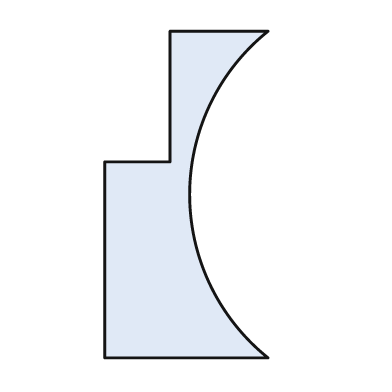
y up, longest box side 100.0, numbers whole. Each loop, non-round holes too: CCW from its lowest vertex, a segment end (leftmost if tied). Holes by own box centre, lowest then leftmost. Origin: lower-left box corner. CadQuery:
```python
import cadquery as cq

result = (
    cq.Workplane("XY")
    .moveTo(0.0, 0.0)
    .lineTo(50.0, 0.0)
    .threePointArc((26.0, 50.0), (50.0, 100.0))
    .lineTo(20.0, 100.0)
    .lineTo(20.0, 60.0)
    .lineTo(0.0, 60.0)
    .close()
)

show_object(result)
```